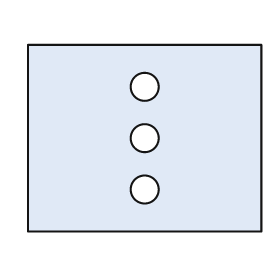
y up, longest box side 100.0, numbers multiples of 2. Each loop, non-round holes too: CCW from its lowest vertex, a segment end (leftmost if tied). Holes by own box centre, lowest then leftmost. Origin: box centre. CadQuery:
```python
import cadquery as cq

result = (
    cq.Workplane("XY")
    .moveTo(-50.0, -40.0)
    .lineTo(50.0, -40.0)
    .lineTo(50.0, 40.0)
    .lineTo(-50.0, 40.0)
    .close()
    .moveTo(0.0, -22.0)
    .circle(6.0)
    .moveTo(0.0, 0.0)
    .circle(6.0)
    .moveTo(0.0, 22.0)
    .circle(6.0)
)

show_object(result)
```